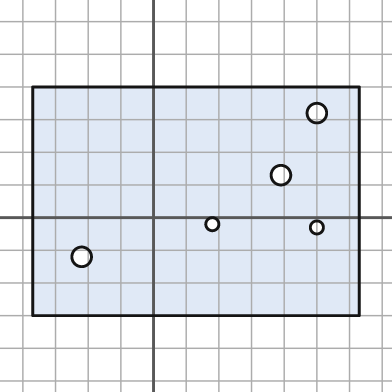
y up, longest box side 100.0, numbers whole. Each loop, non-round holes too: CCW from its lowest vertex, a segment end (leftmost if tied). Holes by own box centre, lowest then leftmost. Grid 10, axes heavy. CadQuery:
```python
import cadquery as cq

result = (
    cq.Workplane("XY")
    .moveTo(-37.0, -30.0)
    .lineTo(63.0, -30.0)
    .lineTo(63.0, 40.0)
    .lineTo(-37.0, 40.0)
    .close()
    .moveTo(-22.0, -12.0)
    .circle(3.0)
    .moveTo(50.0, -3.0)
    .circle(2.0)
    .moveTo(18.0, -2.0)
    .circle(2.0)
    .moveTo(39.0, 13.0)
    .circle(3.0)
    .moveTo(50.0, 32.0)
    .circle(3.0)
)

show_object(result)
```